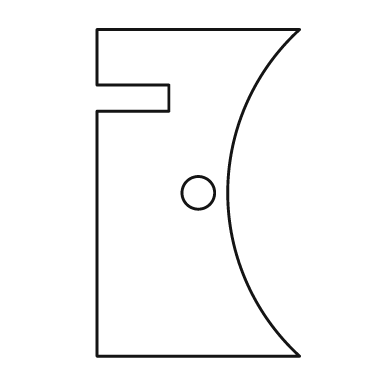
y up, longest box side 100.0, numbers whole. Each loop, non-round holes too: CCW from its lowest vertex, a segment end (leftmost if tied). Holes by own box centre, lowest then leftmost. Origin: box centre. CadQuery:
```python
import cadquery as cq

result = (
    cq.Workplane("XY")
    .moveTo(-31.0, -50.0)
    .lineTo(31.0, -50.0)
    .threePointArc((9.0, 0.0), (31.0, 50.0))
    .lineTo(-31.0, 50.0)
    .lineTo(-31.0, 33.0)
    .lineTo(-9.0, 33.0)
    .lineTo(-9.0, 25.0)
    .lineTo(-31.0, 25.0)
    .close()
    .moveTo(0.0, 0.0)
    .circle(5.0)
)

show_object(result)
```